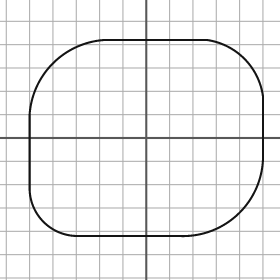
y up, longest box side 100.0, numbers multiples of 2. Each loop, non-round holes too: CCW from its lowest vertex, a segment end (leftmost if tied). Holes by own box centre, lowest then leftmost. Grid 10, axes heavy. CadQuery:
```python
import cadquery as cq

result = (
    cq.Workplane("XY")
    .moveTo(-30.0, -42.0)
    .lineTo(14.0, -42.0)
    .threePointArc((40.0, -32.0), (50.0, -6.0))
    .lineTo(50.0, 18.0)
    .threePointArc((42.0, 34.0), (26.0, 42.0))
    .lineTo(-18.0, 42.0)
    .threePointArc((-40.0, 32.0), (-50.0, 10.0))
    .lineTo(-50.0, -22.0)
    .threePointArc((-44.0, -36.0), (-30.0, -42.0))
    .close()
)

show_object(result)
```